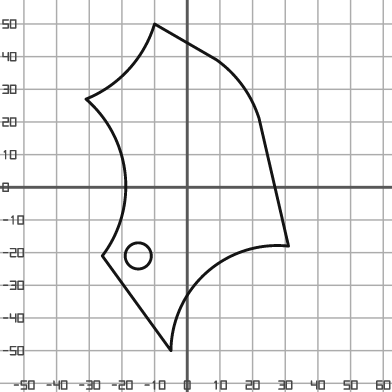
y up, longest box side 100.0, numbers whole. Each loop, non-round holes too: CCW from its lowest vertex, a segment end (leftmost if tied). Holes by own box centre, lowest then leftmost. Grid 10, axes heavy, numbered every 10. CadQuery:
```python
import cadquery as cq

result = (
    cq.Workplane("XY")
    .moveTo(-5.0, -50.0)
    .threePointArc((6.0, -26.0), (31.0, -18.0))
    .lineTo(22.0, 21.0)
    .threePointArc((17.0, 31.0), (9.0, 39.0))
    .lineTo(-10.0, 50.0)
    .threePointArc((-18.0, 36.0), (-31.0, 27.0))
    .threePointArc((-19.0, 4.0), (-26.0, -21.0))
    .close()
    .moveTo(-15.0, -21.0)
    .circle(4.0)
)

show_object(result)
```